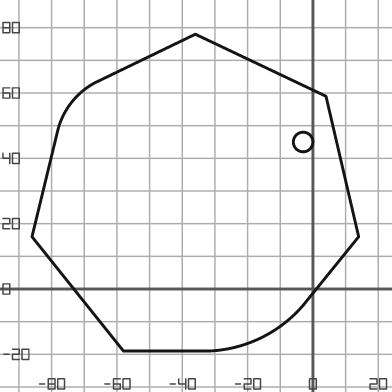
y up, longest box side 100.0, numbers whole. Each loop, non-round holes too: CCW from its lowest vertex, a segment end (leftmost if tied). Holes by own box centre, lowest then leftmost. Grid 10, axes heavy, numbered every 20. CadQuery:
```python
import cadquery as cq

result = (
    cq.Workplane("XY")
    .moveTo(-58.0, -19.0)
    .lineTo(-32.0, -19.0)
    .threePointArc((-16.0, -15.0), (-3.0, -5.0))
    .lineTo(14.0, 16.0)
    .lineTo(4.0, 59.0)
    .lineTo(-36.0, 78.0)
    .lineTo(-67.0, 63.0)
    .threePointArc((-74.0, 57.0), (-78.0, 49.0))
    .lineTo(-86.0, 16.0)
    .close()
    .moveTo(-3.0, 45.0)
    .circle(3.0)
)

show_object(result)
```